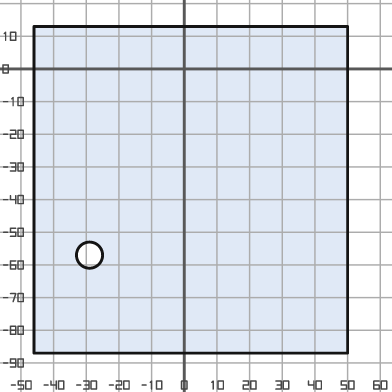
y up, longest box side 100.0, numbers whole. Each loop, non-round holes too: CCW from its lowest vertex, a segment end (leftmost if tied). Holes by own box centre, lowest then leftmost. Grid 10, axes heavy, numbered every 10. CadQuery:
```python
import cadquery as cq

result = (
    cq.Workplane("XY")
    .moveTo(-46.0, -87.0)
    .lineTo(50.0, -87.0)
    .lineTo(50.0, 13.0)
    .lineTo(-46.0, 13.0)
    .close()
    .moveTo(-29.0, -57.0)
    .circle(4.0)
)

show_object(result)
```